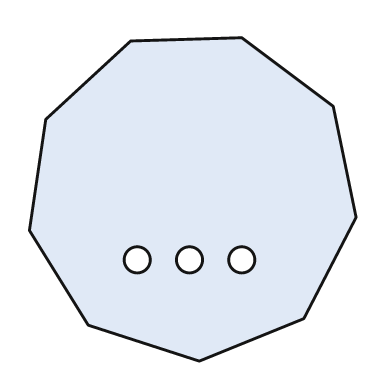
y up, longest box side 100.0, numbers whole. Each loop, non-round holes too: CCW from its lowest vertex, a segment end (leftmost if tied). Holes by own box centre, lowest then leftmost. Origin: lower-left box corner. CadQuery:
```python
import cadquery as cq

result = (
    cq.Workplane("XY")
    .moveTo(52.0, 0.0)
    .lineTo(84.0, 13.0)
    .lineTo(100.0, 44.0)
    .lineTo(93.0, 78.0)
    .lineTo(65.0, 99.0)
    .lineTo(31.0, 98.0)
    .lineTo(5.0, 74.0)
    .lineTo(0.0, 40.0)
    .lineTo(18.0, 11.0)
    .close()
    .moveTo(33.0, 31.0)
    .circle(4.0)
    .moveTo(49.0, 31.0)
    .circle(4.0)
    .moveTo(65.0, 31.0)
    .circle(4.0)
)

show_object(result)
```